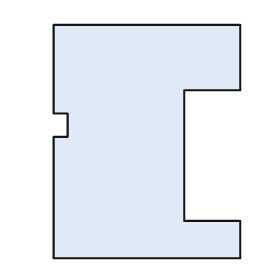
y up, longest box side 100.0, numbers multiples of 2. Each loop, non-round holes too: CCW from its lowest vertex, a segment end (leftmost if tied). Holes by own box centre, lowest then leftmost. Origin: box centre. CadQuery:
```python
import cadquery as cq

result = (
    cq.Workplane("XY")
    .moveTo(-40.0, -50.0)
    .lineTo(40.0, -50.0)
    .lineTo(40.0, -34.0)
    .lineTo(16.0, -34.0)
    .lineTo(16.0, 22.0)
    .lineTo(40.0, 22.0)
    .lineTo(40.0, 50.0)
    .lineTo(-40.0, 50.0)
    .lineTo(-40.0, 12.0)
    .lineTo(-34.0, 12.0)
    .lineTo(-34.0, 2.0)
    .lineTo(-40.0, 2.0)
    .close()
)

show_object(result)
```